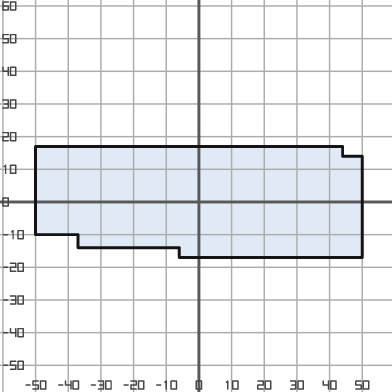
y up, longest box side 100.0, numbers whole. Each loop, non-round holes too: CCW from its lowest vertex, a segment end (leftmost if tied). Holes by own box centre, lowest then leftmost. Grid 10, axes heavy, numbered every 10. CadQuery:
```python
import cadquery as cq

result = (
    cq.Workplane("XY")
    .moveTo(-6.0, -17.0)
    .lineTo(50.0, -17.0)
    .lineTo(50.0, 14.0)
    .lineTo(44.0, 14.0)
    .lineTo(44.0, 17.0)
    .lineTo(-50.0, 17.0)
    .lineTo(-50.0, -10.0)
    .lineTo(-37.0, -10.0)
    .lineTo(-37.0, -14.0)
    .lineTo(-6.0, -14.0)
    .close()
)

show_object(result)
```